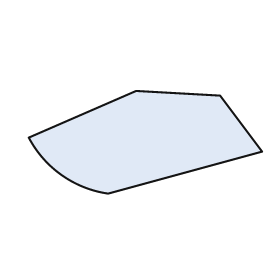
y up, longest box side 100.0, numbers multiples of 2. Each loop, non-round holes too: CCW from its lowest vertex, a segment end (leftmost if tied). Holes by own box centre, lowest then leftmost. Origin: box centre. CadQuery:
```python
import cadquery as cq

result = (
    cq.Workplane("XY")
    .moveTo(-16.0, -22.0)
    .lineTo(50.0, -4.0)
    .lineTo(32.0, 20.0)
    .lineTo(-4.0, 22.0)
    .lineTo(-50.0, 2.0)
    .threePointArc((-36.0, -14.0), (-16.0, -22.0))
    .close()
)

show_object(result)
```